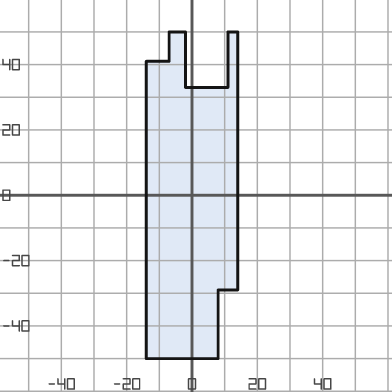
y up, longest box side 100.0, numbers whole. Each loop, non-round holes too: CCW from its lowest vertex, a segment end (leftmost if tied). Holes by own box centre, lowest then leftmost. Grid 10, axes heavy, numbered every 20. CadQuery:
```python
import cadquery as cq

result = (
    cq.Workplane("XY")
    .moveTo(-14.0, -50.0)
    .lineTo(8.0, -50.0)
    .lineTo(8.0, -29.0)
    .lineTo(14.0, -29.0)
    .lineTo(14.0, 50.0)
    .lineTo(11.0, 50.0)
    .lineTo(11.0, 33.0)
    .lineTo(-2.0, 33.0)
    .lineTo(-2.0, 50.0)
    .lineTo(-7.0, 50.0)
    .lineTo(-7.0, 41.0)
    .lineTo(-14.0, 41.0)
    .close()
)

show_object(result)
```